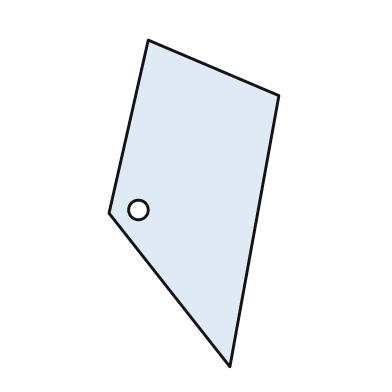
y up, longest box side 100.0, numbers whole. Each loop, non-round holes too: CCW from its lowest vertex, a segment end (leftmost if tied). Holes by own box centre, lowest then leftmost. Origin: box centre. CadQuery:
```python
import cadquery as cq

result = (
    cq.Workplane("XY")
    .moveTo(11.0, -50.0)
    .lineTo(26.0, 33.0)
    .lineTo(-14.0, 50.0)
    .lineTo(-26.0, -3.0)
    .close()
    .moveTo(-17.0, -2.0)
    .circle(3.0)
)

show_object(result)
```